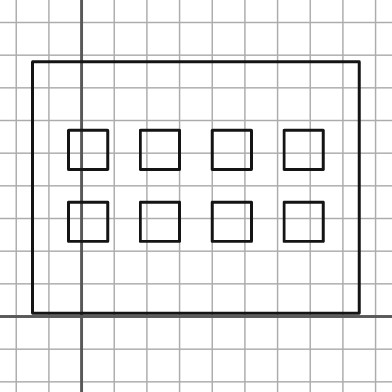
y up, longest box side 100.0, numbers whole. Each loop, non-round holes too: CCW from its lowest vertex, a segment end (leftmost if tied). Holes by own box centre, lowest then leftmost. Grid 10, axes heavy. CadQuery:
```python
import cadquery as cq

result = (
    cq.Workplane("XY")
    .moveTo(-15.0, 1.0)
    .lineTo(85.0, 1.0)
    .lineTo(85.0, 78.0)
    .lineTo(-15.0, 78.0)
    .close()
    .moveTo(-4.0, 23.0)
    .lineTo(8.0, 23.0)
    .lineTo(8.0, 35.0)
    .lineTo(-4.0, 35.0)
    .close()
    .moveTo(18.0, 23.0)
    .lineTo(30.0, 23.0)
    .lineTo(30.0, 35.0)
    .lineTo(18.0, 35.0)
    .close()
    .moveTo(40.0, 23.0)
    .lineTo(52.0, 23.0)
    .lineTo(52.0, 35.0)
    .lineTo(40.0, 35.0)
    .close()
    .moveTo(62.0, 23.0)
    .lineTo(74.0, 23.0)
    .lineTo(74.0, 35.0)
    .lineTo(62.0, 35.0)
    .close()
    .moveTo(-4.0, 45.0)
    .lineTo(8.0, 45.0)
    .lineTo(8.0, 57.0)
    .lineTo(-4.0, 57.0)
    .close()
    .moveTo(18.0, 45.0)
    .lineTo(30.0, 45.0)
    .lineTo(30.0, 57.0)
    .lineTo(18.0, 57.0)
    .close()
    .moveTo(40.0, 45.0)
    .lineTo(52.0, 45.0)
    .lineTo(52.0, 57.0)
    .lineTo(40.0, 57.0)
    .close()
    .moveTo(62.0, 45.0)
    .lineTo(74.0, 45.0)
    .lineTo(74.0, 57.0)
    .lineTo(62.0, 57.0)
    .close()
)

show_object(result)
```